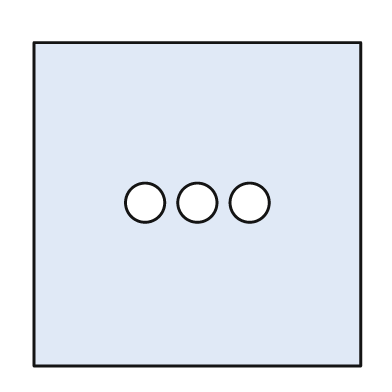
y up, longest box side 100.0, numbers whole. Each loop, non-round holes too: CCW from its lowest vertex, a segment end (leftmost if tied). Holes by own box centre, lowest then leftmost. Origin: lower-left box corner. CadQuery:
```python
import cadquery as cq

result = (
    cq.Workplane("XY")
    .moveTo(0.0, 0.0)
    .lineTo(100.0, 0.0)
    .lineTo(100.0, 99.0)
    .lineTo(0.0, 99.0)
    .close()
    .moveTo(34.0, 50.0)
    .circle(6.0)
    .moveTo(50.0, 50.0)
    .circle(6.0)
    .moveTo(66.0, 50.0)
    .circle(6.0)
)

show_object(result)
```